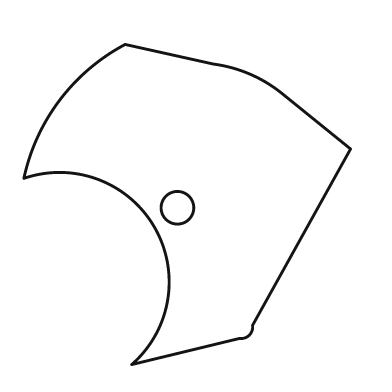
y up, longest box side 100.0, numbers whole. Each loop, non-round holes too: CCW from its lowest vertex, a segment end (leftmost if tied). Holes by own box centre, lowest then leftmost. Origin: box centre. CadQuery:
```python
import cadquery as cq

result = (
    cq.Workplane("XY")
    .moveTo(-17.0, -49.0)
    .lineTo(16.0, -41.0)
    .threePointArc((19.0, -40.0), (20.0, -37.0))
    .lineTo(50.0, 17.0)
    .lineTo(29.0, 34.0)
    .threePointArc((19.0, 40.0), (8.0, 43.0))
    .lineTo(-19.0, 49.0)
    .threePointArc((-39.0, 32.0), (-50.0, 8.0))
    .threePointArc((-10.0, -7.0), (-17.0, -49.0))
    .close()
    .moveTo(-3.0, -1.0)
    .circle(5.0)
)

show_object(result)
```